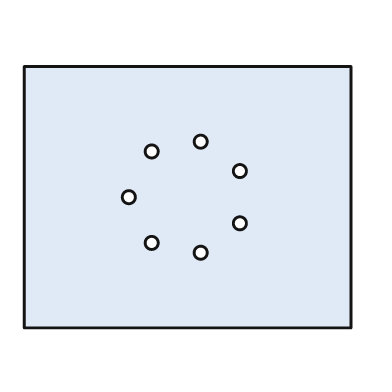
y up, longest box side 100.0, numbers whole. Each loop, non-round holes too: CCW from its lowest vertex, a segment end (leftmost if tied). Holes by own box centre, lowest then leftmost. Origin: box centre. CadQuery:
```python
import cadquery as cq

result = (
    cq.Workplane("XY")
    .moveTo(-50.0, -40.0)
    .lineTo(50.0, -40.0)
    .lineTo(50.0, 40.0)
    .lineTo(-50.0, 40.0)
    .close()
    .moveTo(4.0, -17.0)
    .circle(2.0)
    .moveTo(-11.0, -14.0)
    .circle(2.0)
    .moveTo(16.0, -8.0)
    .circle(2.0)
    .moveTo(-18.0, 0.0)
    .circle(2.0)
    .moveTo(16.0, 8.0)
    .circle(2.0)
    .moveTo(-11.0, 14.0)
    .circle(2.0)
    .moveTo(4.0, 17.0)
    .circle(2.0)
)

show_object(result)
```